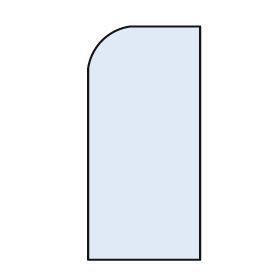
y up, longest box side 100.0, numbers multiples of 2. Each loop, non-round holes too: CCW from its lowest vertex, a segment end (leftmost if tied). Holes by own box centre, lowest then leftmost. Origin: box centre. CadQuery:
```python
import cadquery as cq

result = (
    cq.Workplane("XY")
    .moveTo(-24.0, -50.0)
    .lineTo(24.0, -50.0)
    .lineTo(24.0, 50.0)
    .lineTo(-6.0, 50.0)
    .threePointArc((-18.0, 44.0), (-24.0, 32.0))
    .close()
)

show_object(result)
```